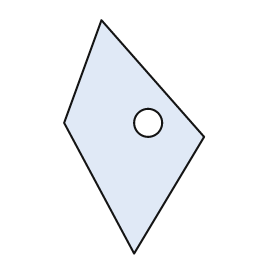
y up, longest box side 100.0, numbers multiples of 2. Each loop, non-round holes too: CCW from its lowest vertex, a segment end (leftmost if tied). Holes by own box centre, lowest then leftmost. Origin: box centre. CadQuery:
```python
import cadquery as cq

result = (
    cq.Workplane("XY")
    .moveTo(0.0, -50.0)
    .lineTo(30.0, 0.0)
    .lineTo(-14.0, 50.0)
    .lineTo(-30.0, 6.0)
    .close()
    .moveTo(6.0, 6.0)
    .circle(6.0)
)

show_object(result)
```